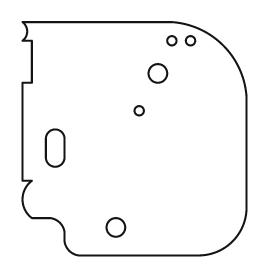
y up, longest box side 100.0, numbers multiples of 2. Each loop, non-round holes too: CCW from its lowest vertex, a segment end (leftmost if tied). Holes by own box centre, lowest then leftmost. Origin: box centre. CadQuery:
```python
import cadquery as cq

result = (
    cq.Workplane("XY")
    .moveTo(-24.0, -50.0)
    .lineTo(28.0, -50.0)
    .threePointArc((42.0, -44.0), (48.0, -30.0))
    .lineTo(48.0, 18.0)
    .threePointArc((38.0, 40.0), (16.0, 50.0))
    .lineTo(-48.0, 50.0)
    .threePointArc((-46.0, 46.0), (-48.0, 42.0))
    .lineTo(-44.0, 42.0)
    .lineTo(-44.0, 24.0)
    .lineTo(-48.0, 24.0)
    .lineTo(-48.0, -18.0)
    .lineTo(-44.0, -18.0)
    .threePointArc((-48.0, -26.0), (-44.0, -34.0))
    .lineTo(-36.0, -34.0)
    .threePointArc((-32.0, -36.0), (-30.0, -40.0))
    .lineTo(-30.0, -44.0)
    .threePointArc((-28.0, -48.0), (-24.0, -50.0))
    .close()
    .moveTo(-8.0, -38.0)
    .circle(4.0)
    .moveTo(-38.0, -8.0)
    .threePointArc((-34.0, -12.0), (-30.0, -8.0))
    .lineTo(-30.0, 0.0)
    .threePointArc((-34.0, 4.0), (-38.0, 0.0))
    .close()
    .moveTo(2.0, 12.0)
    .circle(2.0)
    .moveTo(10.0, 28.0)
    .circle(4.0)
    .moveTo(16.0, 42.0)
    .circle(2.0)
    .moveTo(24.0, 42.0)
    .circle(2.0)
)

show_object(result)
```